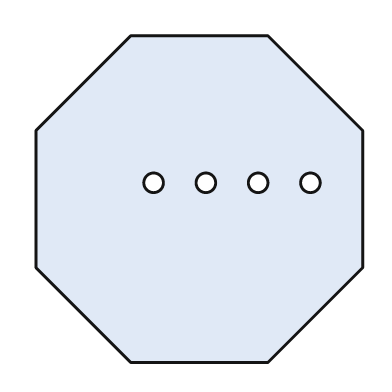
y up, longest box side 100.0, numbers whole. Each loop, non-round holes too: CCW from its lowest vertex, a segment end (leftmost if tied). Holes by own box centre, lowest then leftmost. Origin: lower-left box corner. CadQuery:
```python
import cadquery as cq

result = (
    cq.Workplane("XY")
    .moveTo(29.0, 0.0)
    .lineTo(71.0, 0.0)
    .lineTo(100.0, 29.0)
    .lineTo(100.0, 71.0)
    .lineTo(71.0, 100.0)
    .lineTo(29.0, 100.0)
    .lineTo(0.0, 71.0)
    .lineTo(0.0, 29.0)
    .close()
    .moveTo(36.0, 55.0)
    .circle(3.0)
    .moveTo(52.0, 55.0)
    .circle(3.0)
    .moveTo(68.0, 55.0)
    .circle(3.0)
    .moveTo(84.0, 55.0)
    .circle(3.0)
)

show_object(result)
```